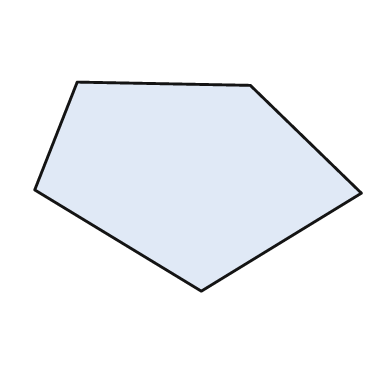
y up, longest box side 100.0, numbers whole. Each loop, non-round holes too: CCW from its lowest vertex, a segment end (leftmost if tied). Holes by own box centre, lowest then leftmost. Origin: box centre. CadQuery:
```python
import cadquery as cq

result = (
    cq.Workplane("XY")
    .moveTo(1.0, -32.0)
    .lineTo(50.0, -2.0)
    .lineTo(16.0, 31.0)
    .lineTo(-37.0, 32.0)
    .lineTo(-50.0, -1.0)
    .close()
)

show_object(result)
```